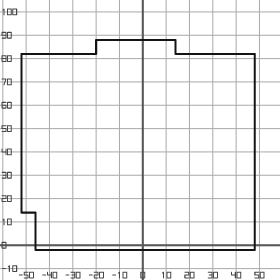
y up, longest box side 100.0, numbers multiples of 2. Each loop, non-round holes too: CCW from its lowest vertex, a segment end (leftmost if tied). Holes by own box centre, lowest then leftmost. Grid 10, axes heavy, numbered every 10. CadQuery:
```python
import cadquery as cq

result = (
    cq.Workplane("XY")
    .moveTo(-46.0, -2.0)
    .lineTo(48.0, -2.0)
    .lineTo(48.0, 82.0)
    .lineTo(14.0, 82.0)
    .lineTo(14.0, 88.0)
    .lineTo(-20.0, 88.0)
    .lineTo(-20.0, 82.0)
    .lineTo(-52.0, 82.0)
    .lineTo(-52.0, 14.0)
    .lineTo(-46.0, 14.0)
    .close()
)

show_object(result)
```